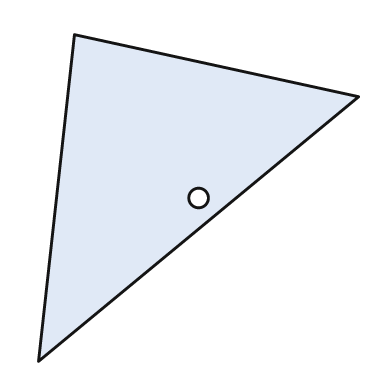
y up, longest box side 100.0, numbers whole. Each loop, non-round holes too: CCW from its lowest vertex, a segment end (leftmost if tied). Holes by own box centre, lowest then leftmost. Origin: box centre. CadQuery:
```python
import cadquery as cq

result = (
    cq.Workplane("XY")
    .moveTo(-49.0, -50.0)
    .lineTo(49.0, 31.0)
    .lineTo(-38.0, 50.0)
    .close()
    .moveTo(0.0, 0.0)
    .circle(3.0)
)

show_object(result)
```